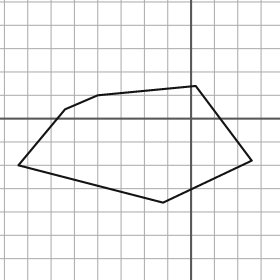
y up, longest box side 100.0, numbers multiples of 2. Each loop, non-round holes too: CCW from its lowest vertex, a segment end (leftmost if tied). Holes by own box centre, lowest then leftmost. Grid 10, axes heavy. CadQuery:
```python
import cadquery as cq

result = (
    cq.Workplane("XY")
    .moveTo(-12.0, -36.0)
    .lineTo(26.0, -18.0)
    .lineTo(2.0, 14.0)
    .lineTo(-40.0, 10.0)
    .lineTo(-54.0, 4.0)
    .lineTo(-74.0, -20.0)
    .close()
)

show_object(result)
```